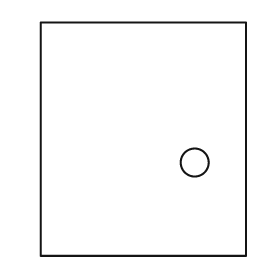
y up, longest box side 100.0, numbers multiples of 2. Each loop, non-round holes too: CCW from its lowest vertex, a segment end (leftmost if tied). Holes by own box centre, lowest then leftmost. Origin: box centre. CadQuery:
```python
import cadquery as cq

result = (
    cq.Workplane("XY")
    .moveTo(-44.0, -50.0)
    .lineTo(44.0, -50.0)
    .lineTo(44.0, 50.0)
    .lineTo(-44.0, 50.0)
    .close()
    .moveTo(22.0, -10.0)
    .circle(6.0)
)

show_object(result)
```